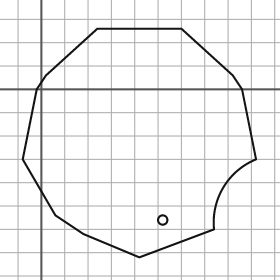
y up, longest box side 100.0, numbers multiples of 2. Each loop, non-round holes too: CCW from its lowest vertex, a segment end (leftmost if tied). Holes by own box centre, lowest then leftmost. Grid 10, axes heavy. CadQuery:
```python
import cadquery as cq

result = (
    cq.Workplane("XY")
    .moveTo(42.0, -72.0)
    .lineTo(74.0, -60.0)
    .threePointArc((78.0, -42.0), (92.0, -30.0))
    .lineTo(86.0, 0.0)
    .lineTo(82.0, 6.0)
    .lineTo(60.0, 26.0)
    .lineTo(24.0, 26.0)
    .lineTo(2.0, 6.0)
    .lineTo(-2.0, 0.0)
    .lineTo(-8.0, -30.0)
    .lineTo(6.0, -54.0)
    .lineTo(18.0, -62.0)
    .close()
    .moveTo(52.0, -56.0)
    .circle(2.0)
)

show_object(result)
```